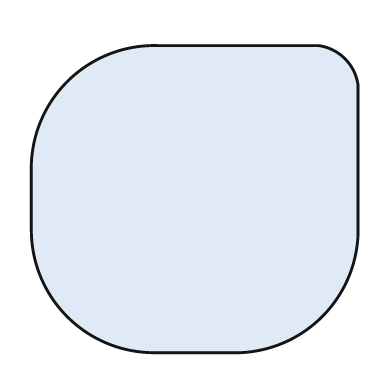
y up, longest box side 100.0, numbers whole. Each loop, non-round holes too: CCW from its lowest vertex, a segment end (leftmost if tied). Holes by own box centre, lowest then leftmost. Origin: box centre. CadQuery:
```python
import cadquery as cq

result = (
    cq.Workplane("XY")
    .moveTo(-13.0, -47.0)
    .lineTo(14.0, -47.0)
    .threePointArc((39.0, -36.0), (50.0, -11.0))
    .lineTo(50.0, 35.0)
    .threePointArc((46.0, 43.0), (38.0, 47.0))
    .lineTo(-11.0, 47.0)
    .threePointArc((-39.0, 36.0), (-50.0, 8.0))
    .lineTo(-50.0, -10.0)
    .threePointArc((-39.0, -36.0), (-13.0, -47.0))
    .close()
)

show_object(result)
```